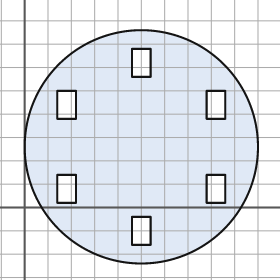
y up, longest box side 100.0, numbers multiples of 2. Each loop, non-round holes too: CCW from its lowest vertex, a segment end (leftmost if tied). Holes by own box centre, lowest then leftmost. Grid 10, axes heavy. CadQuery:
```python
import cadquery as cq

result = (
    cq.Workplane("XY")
    .moveTo(50.0, 26.0)
    .circle(50.0)
    .moveTo(46.0, -16.0)
    .lineTo(54.0, -16.0)
    .lineTo(54.0, -4.0)
    .lineTo(46.0, -4.0)
    .close()
    .moveTo(14.0, 2.0)
    .lineTo(22.0, 2.0)
    .lineTo(22.0, 14.0)
    .lineTo(14.0, 14.0)
    .close()
    .moveTo(78.0, 2.0)
    .lineTo(86.0, 2.0)
    .lineTo(86.0, 14.0)
    .lineTo(78.0, 14.0)
    .close()
    .moveTo(14.0, 38.0)
    .lineTo(22.0, 38.0)
    .lineTo(22.0, 50.0)
    .lineTo(14.0, 50.0)
    .close()
    .moveTo(78.0, 38.0)
    .lineTo(86.0, 38.0)
    .lineTo(86.0, 50.0)
    .lineTo(78.0, 50.0)
    .close()
    .moveTo(46.0, 56.0)
    .lineTo(54.0, 56.0)
    .lineTo(54.0, 68.0)
    .lineTo(46.0, 68.0)
    .close()
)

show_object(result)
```